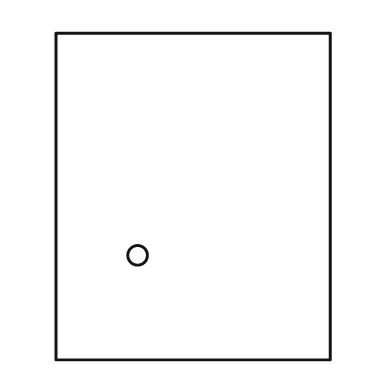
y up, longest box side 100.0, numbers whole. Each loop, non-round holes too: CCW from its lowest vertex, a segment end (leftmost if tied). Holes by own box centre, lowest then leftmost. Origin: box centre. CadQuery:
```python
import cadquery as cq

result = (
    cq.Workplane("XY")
    .moveTo(-42.0, -50.0)
    .lineTo(42.0, -50.0)
    .lineTo(42.0, 50.0)
    .lineTo(-42.0, 50.0)
    .close()
    .moveTo(-17.0, -18.0)
    .circle(3.0)
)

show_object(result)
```